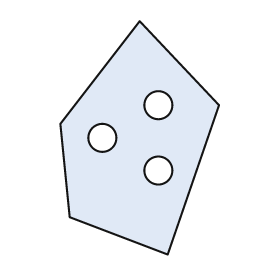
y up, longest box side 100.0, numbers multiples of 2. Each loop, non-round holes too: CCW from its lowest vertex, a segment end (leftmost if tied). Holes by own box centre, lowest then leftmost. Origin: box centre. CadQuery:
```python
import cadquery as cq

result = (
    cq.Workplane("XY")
    .moveTo(12.0, -50.0)
    .lineTo(34.0, 14.0)
    .lineTo(0.0, 50.0)
    .lineTo(-34.0, 6.0)
    .lineTo(-30.0, -34.0)
    .close()
    .moveTo(8.0, -14.0)
    .circle(6.0)
    .moveTo(-16.0, 0.0)
    .circle(6.0)
    .moveTo(8.0, 14.0)
    .circle(6.0)
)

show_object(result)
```